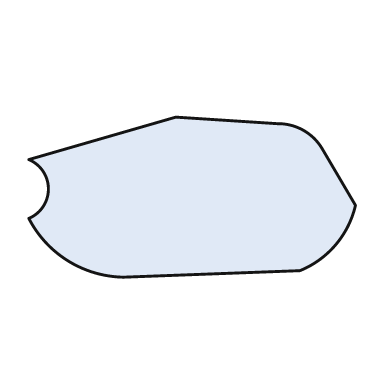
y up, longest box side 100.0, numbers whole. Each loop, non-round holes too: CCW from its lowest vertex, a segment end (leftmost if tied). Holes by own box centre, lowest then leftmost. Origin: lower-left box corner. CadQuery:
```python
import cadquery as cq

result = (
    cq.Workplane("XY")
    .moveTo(29.0, 0.0)
    .lineTo(83.0, 2.0)
    .threePointArc((94.0, 10.0), (100.0, 22.0))
    .lineTo(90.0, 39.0)
    .threePointArc((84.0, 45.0), (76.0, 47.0))
    .lineTo(45.0, 49.0)
    .lineTo(0.0, 36.0)
    .threePointArc((6.0, 27.0), (0.0, 18.0))
    .threePointArc((12.0, 5.0), (29.0, 0.0))
    .close()
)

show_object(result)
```